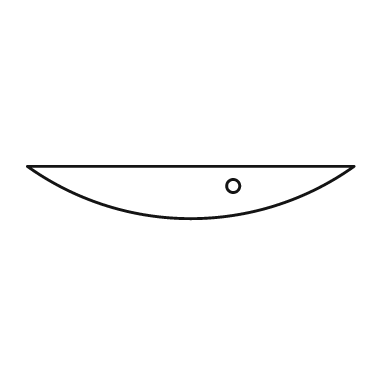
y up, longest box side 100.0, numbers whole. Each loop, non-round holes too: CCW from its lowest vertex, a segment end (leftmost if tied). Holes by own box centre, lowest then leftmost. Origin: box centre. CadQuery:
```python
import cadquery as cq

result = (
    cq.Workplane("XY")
    .moveTo(-50.0, 8.0)
    .threePointArc((0.0, -8.0), (50.0, 8.0))
    .close()
    .moveTo(13.0, 2.0)
    .circle(2.0)
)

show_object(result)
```